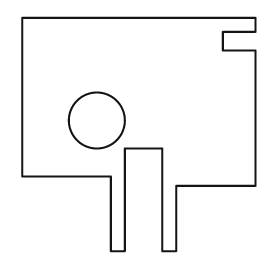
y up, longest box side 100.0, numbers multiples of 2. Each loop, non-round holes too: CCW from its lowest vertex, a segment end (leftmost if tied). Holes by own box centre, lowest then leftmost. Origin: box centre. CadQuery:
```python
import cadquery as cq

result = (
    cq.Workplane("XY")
    .moveTo(-12.0, -50.0)
    .lineTo(-6.0, -50.0)
    .lineTo(-6.0, -6.0)
    .lineTo(10.0, -6.0)
    .lineTo(10.0, -50.0)
    .lineTo(16.0, -50.0)
    .lineTo(16.0, -22.0)
    .lineTo(50.0, -22.0)
    .lineTo(50.0, 36.0)
    .lineTo(36.0, 36.0)
    .lineTo(36.0, 44.0)
    .lineTo(50.0, 44.0)
    .lineTo(50.0, 50.0)
    .lineTo(-50.0, 50.0)
    .lineTo(-50.0, -18.0)
    .lineTo(-12.0, -18.0)
    .close()
    .moveTo(-18.0, 6.0)
    .circle(12.0)
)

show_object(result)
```